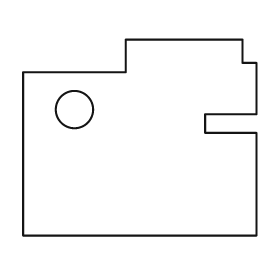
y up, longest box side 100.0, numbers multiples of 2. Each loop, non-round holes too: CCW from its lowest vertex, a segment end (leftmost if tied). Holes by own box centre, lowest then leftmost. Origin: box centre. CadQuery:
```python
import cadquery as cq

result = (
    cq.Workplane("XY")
    .moveTo(-50.0, -42.0)
    .lineTo(50.0, -42.0)
    .lineTo(50.0, 2.0)
    .lineTo(28.0, 2.0)
    .lineTo(28.0, 10.0)
    .lineTo(50.0, 10.0)
    .lineTo(50.0, 32.0)
    .lineTo(44.0, 32.0)
    .lineTo(44.0, 42.0)
    .lineTo(-6.0, 42.0)
    .lineTo(-6.0, 28.0)
    .lineTo(-50.0, 28.0)
    .close()
    .moveTo(-28.0, 12.0)
    .circle(8.0)
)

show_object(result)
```